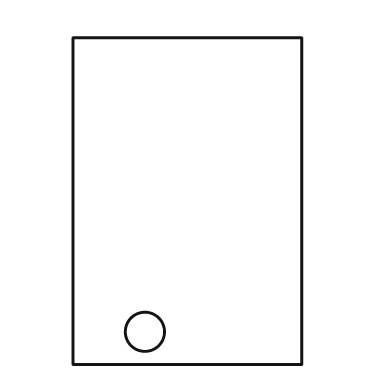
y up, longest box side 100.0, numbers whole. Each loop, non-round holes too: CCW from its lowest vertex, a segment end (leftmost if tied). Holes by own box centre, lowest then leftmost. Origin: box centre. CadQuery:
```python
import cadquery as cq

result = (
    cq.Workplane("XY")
    .moveTo(-35.0, -50.0)
    .lineTo(35.0, -50.0)
    .lineTo(35.0, 50.0)
    .lineTo(-35.0, 50.0)
    .close()
    .moveTo(-13.0, -40.0)
    .circle(6.0)
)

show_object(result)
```